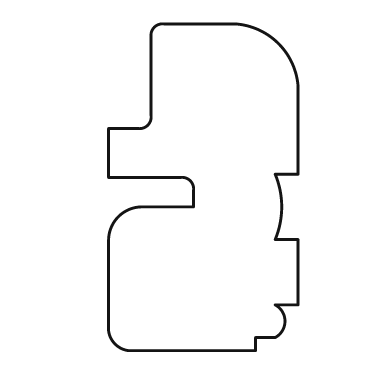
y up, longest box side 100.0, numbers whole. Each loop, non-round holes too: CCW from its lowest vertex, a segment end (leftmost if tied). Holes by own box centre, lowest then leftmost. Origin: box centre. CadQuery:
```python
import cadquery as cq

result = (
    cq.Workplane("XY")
    .moveTo(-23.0, -50.0)
    .lineTo(16.0, -50.0)
    .lineTo(16.0, -46.0)
    .lineTo(22.0, -46.0)
    .threePointArc((25.0, -41.0), (22.0, -36.0))
    .lineTo(29.0, -36.0)
    .lineTo(29.0, -16.0)
    .lineTo(22.0, -16.0)
    .threePointArc((24.0, -6.0), (22.0, 4.0))
    .lineTo(29.0, 4.0)
    .lineTo(29.0, 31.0)
    .threePointArc((23.0, 44.0), (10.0, 50.0))
    .lineTo(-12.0, 50.0)
    .threePointArc((-15.0, 49.0), (-16.0, 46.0))
    .lineTo(-16.0, 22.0)
    .threePointArc((-17.0, 19.0), (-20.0, 18.0))
    .lineTo(-29.0, 18.0)
    .lineTo(-29.0, 3.0)
    .lineTo(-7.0, 3.0)
    .threePointArc((-4.0, 2.0), (-3.0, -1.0))
    .lineTo(-3.0, -6.0)
    .lineTo(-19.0, -6.0)
    .threePointArc((-26.0, -9.0), (-29.0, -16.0))
    .lineTo(-29.0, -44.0)
    .threePointArc((-27.0, -48.0), (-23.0, -50.0))
    .close()
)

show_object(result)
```